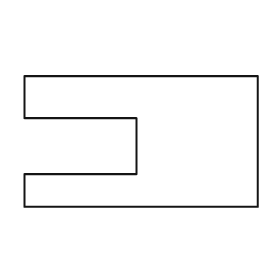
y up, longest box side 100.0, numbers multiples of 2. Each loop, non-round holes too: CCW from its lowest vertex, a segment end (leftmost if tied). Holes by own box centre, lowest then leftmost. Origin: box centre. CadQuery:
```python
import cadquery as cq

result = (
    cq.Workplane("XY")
    .moveTo(-50.0, -28.0)
    .lineTo(50.0, -28.0)
    .lineTo(50.0, 28.0)
    .lineTo(-50.0, 28.0)
    .lineTo(-50.0, 10.0)
    .lineTo(-2.0, 10.0)
    .lineTo(-2.0, -14.0)
    .lineTo(-50.0, -14.0)
    .close()
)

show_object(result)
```